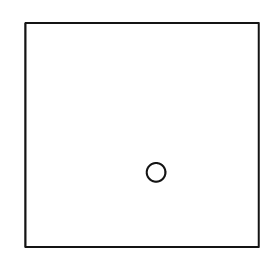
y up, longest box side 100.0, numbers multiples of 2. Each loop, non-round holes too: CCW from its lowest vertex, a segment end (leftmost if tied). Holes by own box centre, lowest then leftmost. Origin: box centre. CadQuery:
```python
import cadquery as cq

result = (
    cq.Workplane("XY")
    .moveTo(-50.0, -48.0)
    .lineTo(50.0, -48.0)
    .lineTo(50.0, 48.0)
    .lineTo(-50.0, 48.0)
    .close()
    .moveTo(6.0, -16.0)
    .circle(4.0)
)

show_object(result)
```